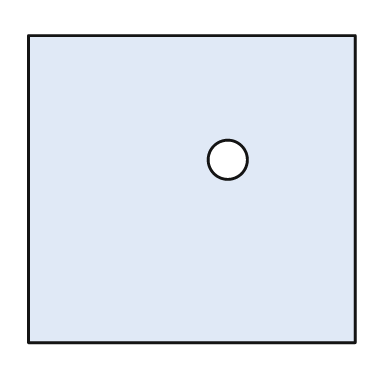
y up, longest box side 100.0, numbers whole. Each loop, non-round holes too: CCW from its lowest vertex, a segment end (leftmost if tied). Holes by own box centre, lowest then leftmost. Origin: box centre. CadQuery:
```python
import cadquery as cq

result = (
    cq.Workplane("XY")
    .moveTo(-50.0, -47.0)
    .lineTo(50.0, -47.0)
    .lineTo(50.0, 47.0)
    .lineTo(-50.0, 47.0)
    .close()
    .moveTo(11.0, 9.0)
    .circle(6.0)
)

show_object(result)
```